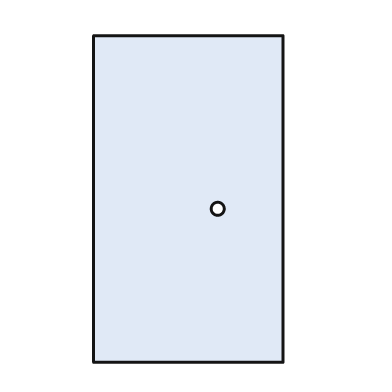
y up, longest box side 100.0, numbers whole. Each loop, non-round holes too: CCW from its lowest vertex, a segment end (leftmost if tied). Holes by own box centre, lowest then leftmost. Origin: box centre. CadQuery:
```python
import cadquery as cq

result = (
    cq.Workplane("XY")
    .moveTo(-29.0, -50.0)
    .lineTo(29.0, -50.0)
    .lineTo(29.0, 50.0)
    .lineTo(-29.0, 50.0)
    .close()
    .moveTo(9.0, -3.0)
    .circle(2.0)
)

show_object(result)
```